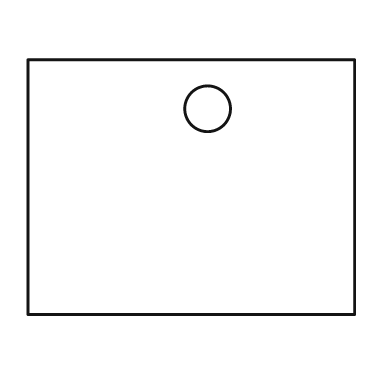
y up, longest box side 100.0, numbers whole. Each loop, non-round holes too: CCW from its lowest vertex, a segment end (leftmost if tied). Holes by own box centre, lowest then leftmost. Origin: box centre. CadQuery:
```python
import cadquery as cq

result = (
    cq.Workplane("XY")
    .moveTo(-50.0, -39.0)
    .lineTo(50.0, -39.0)
    .lineTo(50.0, 39.0)
    .lineTo(-50.0, 39.0)
    .close()
    .moveTo(5.0, 24.0)
    .circle(7.0)
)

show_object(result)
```